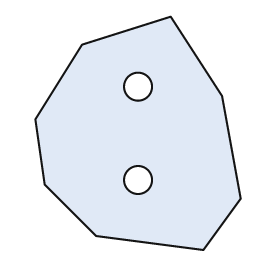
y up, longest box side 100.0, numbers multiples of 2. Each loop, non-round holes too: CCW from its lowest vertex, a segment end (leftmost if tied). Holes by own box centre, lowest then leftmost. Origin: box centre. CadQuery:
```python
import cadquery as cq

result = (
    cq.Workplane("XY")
    .moveTo(28.0, -50.0)
    .lineTo(44.0, -28.0)
    .lineTo(36.0, 16.0)
    .lineTo(14.0, 50.0)
    .lineTo(-24.0, 38.0)
    .lineTo(-44.0, 6.0)
    .lineTo(-40.0, -22.0)
    .lineTo(-18.0, -44.0)
    .close()
    .moveTo(0.0, -20.0)
    .circle(6.0)
    .moveTo(0.0, 20.0)
    .circle(6.0)
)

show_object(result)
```